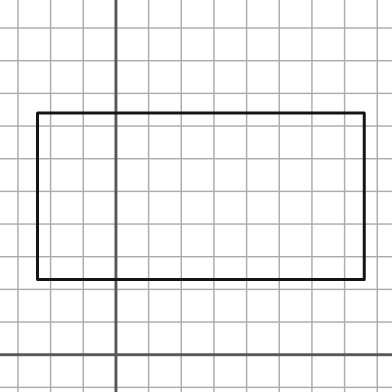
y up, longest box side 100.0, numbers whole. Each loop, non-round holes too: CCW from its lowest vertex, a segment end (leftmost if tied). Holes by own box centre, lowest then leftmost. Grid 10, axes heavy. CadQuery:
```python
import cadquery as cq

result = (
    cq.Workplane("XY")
    .moveTo(-24.0, 23.0)
    .lineTo(76.0, 23.0)
    .lineTo(76.0, 74.0)
    .lineTo(-24.0, 74.0)
    .close()
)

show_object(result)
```